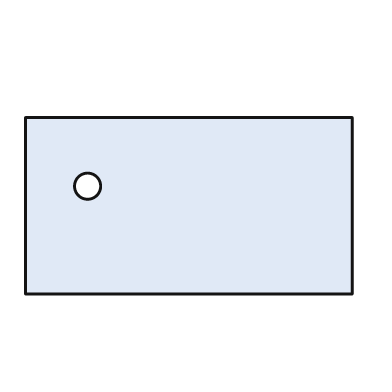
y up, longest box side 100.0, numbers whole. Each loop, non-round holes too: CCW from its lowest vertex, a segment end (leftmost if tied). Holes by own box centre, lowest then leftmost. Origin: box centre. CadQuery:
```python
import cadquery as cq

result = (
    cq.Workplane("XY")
    .moveTo(-50.0, -27.0)
    .lineTo(50.0, -27.0)
    .lineTo(50.0, 27.0)
    .lineTo(-50.0, 27.0)
    .close()
    .moveTo(-31.0, 6.0)
    .circle(4.0)
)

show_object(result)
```